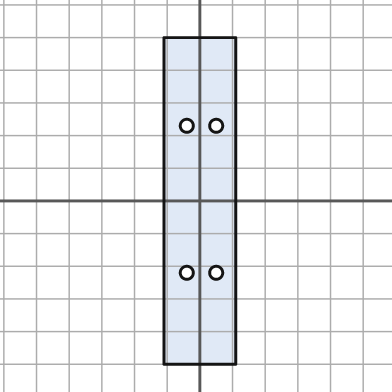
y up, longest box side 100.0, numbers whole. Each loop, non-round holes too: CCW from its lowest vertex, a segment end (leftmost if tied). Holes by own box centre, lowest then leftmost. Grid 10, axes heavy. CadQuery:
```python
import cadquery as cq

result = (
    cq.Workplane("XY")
    .moveTo(-11.0, -50.0)
    .lineTo(11.0, -50.0)
    .lineTo(11.0, 50.0)
    .lineTo(-11.0, 50.0)
    .close()
    .moveTo(-4.0, -22.0)
    .circle(2.0)
    .moveTo(5.0, -22.0)
    .circle(2.0)
    .moveTo(-4.0, 23.0)
    .circle(2.0)
    .moveTo(5.0, 23.0)
    .circle(2.0)
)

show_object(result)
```